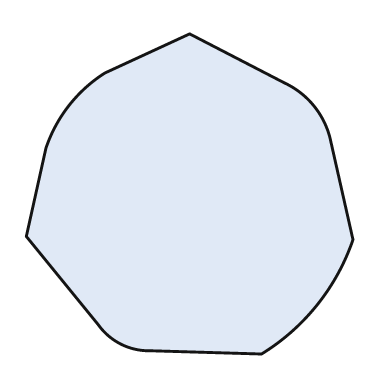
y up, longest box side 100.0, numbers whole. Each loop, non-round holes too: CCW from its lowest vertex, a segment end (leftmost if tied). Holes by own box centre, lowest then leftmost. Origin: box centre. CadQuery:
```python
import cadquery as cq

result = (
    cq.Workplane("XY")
    .moveTo(22.0, -49.0)
    .threePointArc((39.0, -34.0), (50.0, -14.0))
    .lineTo(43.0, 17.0)
    .threePointArc((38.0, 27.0), (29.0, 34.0))
    .lineTo(0.0, 49.0)
    .lineTo(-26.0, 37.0)
    .threePointArc((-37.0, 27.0), (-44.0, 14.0))
    .lineTo(-50.0, -13.0)
    .lineTo(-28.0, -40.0)
    .threePointArc((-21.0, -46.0), (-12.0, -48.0))
    .close()
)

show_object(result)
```